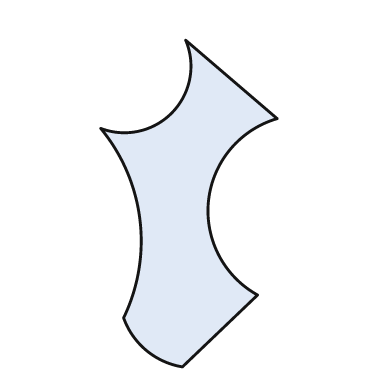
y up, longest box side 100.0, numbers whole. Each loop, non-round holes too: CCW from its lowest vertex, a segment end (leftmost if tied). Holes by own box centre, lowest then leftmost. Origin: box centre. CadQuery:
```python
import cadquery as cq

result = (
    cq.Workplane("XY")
    .moveTo(-2.0, -50.0)
    .lineTo(21.0, -28.0)
    .threePointArc((6.0, 1.0), (27.0, 26.0))
    .lineTo(-1.0, 50.0)
    .threePointArc((-5.0, 28.0), (-27.0, 23.0))
    .threePointArc((-15.0, -5.0), (-20.0, -35.0))
    .threePointArc((-13.0, -45.0), (-2.0, -50.0))
    .close()
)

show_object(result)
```